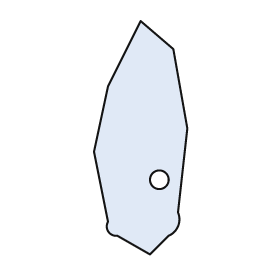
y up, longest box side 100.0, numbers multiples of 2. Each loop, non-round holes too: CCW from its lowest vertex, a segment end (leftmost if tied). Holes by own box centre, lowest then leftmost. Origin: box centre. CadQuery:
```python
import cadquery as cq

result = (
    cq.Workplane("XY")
    .moveTo(4.0, -50.0)
    .lineTo(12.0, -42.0)
    .threePointArc((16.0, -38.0), (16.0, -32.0))
    .lineTo(20.0, 4.0)
    .lineTo(14.0, 38.0)
    .lineTo(0.0, 50.0)
    .lineTo(-14.0, 22.0)
    .lineTo(-20.0, -6.0)
    .lineTo(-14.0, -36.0)
    .threePointArc((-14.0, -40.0), (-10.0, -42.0))
    .close()
    .moveTo(8.0, -18.0)
    .circle(4.0)
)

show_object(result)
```